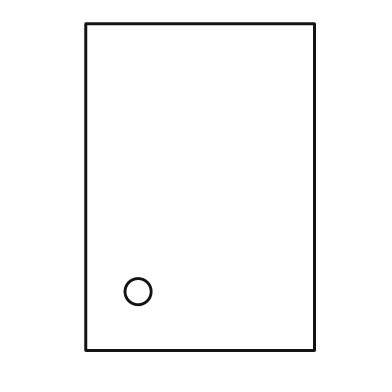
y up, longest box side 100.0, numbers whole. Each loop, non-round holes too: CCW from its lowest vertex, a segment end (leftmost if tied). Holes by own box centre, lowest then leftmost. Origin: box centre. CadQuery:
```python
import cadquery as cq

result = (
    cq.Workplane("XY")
    .moveTo(-35.0, -50.0)
    .lineTo(35.0, -50.0)
    .lineTo(35.0, 50.0)
    .lineTo(-35.0, 50.0)
    .close()
    .moveTo(-19.0, -32.0)
    .circle(4.0)
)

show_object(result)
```